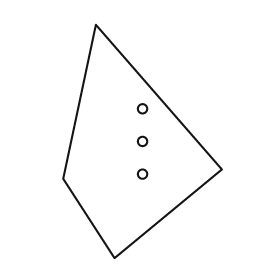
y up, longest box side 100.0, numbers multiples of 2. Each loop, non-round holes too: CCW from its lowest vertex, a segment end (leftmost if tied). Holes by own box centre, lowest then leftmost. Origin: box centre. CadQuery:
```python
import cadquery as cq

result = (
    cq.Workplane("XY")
    .moveTo(-12.0, -50.0)
    .lineTo(34.0, -12.0)
    .lineTo(-20.0, 50.0)
    .lineTo(-34.0, -16.0)
    .close()
    .moveTo(0.0, -14.0)
    .circle(2.0)
    .moveTo(0.0, 0.0)
    .circle(2.0)
    .moveTo(0.0, 14.0)
    .circle(2.0)
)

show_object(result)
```